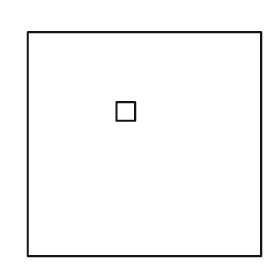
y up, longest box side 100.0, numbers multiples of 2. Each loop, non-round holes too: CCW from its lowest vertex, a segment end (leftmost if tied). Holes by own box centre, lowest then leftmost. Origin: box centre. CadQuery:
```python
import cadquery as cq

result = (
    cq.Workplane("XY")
    .moveTo(-50.0, -48.0)
    .lineTo(50.0, -48.0)
    .lineTo(50.0, 48.0)
    .lineTo(-50.0, 48.0)
    .close()
    .moveTo(-12.0, 10.0)
    .lineTo(-4.0, 10.0)
    .lineTo(-4.0, 18.0)
    .lineTo(-12.0, 18.0)
    .close()
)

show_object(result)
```